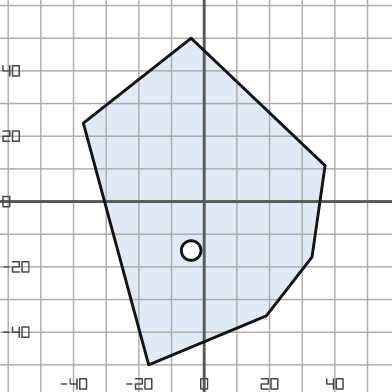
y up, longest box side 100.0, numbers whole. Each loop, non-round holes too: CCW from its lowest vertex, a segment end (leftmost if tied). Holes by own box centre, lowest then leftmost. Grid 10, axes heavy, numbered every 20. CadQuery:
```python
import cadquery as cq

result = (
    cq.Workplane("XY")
    .moveTo(-17.0, -50.0)
    .lineTo(19.0, -35.0)
    .lineTo(33.0, -17.0)
    .lineTo(37.0, 11.0)
    .lineTo(-4.0, 50.0)
    .lineTo(-37.0, 24.0)
    .close()
    .moveTo(-4.0, -15.0)
    .circle(3.0)
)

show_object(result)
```